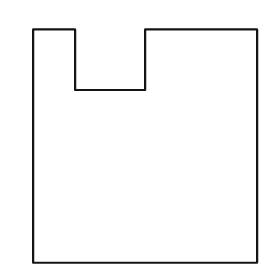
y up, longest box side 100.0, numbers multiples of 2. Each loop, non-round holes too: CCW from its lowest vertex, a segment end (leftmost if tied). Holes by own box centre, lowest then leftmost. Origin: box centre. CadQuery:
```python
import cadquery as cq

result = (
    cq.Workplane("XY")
    .moveTo(-48.0, -50.0)
    .lineTo(48.0, -50.0)
    .lineTo(48.0, 50.0)
    .lineTo(0.0, 50.0)
    .lineTo(0.0, 24.0)
    .lineTo(-30.0, 24.0)
    .lineTo(-30.0, 50.0)
    .lineTo(-48.0, 50.0)
    .close()
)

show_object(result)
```